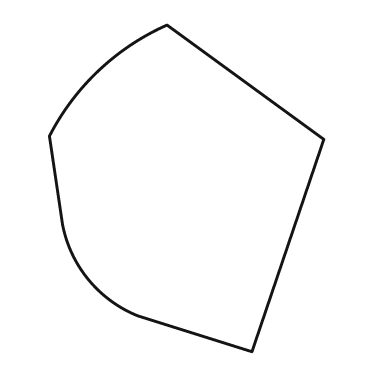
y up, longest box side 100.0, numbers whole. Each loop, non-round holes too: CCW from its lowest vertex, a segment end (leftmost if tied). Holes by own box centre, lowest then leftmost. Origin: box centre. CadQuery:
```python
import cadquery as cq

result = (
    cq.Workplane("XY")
    .moveTo(20.0, -50.0)
    .lineTo(42.0, 15.0)
    .lineTo(-6.0, 50.0)
    .threePointArc((-27.0, 36.0), (-42.0, 16.0))
    .lineTo(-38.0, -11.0)
    .threePointArc((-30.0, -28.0), (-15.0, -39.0))
    .close()
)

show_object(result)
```